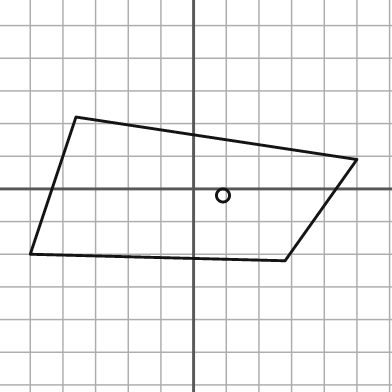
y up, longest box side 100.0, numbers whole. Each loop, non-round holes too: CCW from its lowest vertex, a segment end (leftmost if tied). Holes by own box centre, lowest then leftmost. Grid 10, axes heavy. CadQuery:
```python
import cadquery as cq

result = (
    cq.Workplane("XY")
    .moveTo(28.0, -22.0)
    .lineTo(50.0, 9.0)
    .lineTo(-36.0, 22.0)
    .lineTo(-50.0, -20.0)
    .close()
    .moveTo(9.0, -2.0)
    .circle(2.0)
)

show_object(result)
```